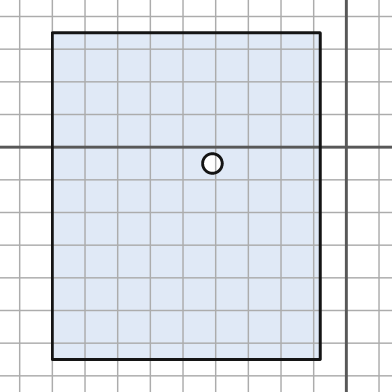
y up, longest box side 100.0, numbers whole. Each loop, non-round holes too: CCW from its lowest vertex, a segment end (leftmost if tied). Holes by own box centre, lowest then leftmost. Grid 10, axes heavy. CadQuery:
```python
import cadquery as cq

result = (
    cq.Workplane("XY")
    .moveTo(-90.0, -65.0)
    .lineTo(-8.0, -65.0)
    .lineTo(-8.0, 35.0)
    .lineTo(-90.0, 35.0)
    .close()
    .moveTo(-41.0, -5.0)
    .circle(3.0)
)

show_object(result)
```